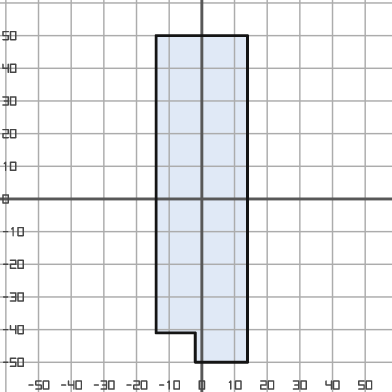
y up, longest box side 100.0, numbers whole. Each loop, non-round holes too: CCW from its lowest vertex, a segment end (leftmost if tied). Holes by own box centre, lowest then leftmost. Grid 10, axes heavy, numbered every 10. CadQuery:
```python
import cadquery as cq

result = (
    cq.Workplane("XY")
    .moveTo(-2.0, -50.0)
    .lineTo(14.0, -50.0)
    .lineTo(14.0, 50.0)
    .lineTo(-14.0, 50.0)
    .lineTo(-14.0, -41.0)
    .lineTo(-2.0, -41.0)
    .close()
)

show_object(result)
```